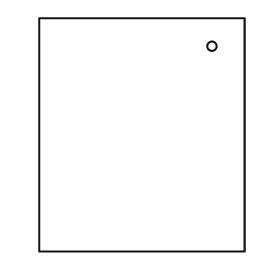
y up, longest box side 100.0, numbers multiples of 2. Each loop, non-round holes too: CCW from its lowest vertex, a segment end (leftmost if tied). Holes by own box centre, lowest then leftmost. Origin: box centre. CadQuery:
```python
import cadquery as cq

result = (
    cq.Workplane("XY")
    .moveTo(-44.0, -50.0)
    .lineTo(44.0, -50.0)
    .lineTo(44.0, 50.0)
    .lineTo(-44.0, 50.0)
    .close()
    .moveTo(30.0, 38.0)
    .circle(2.0)
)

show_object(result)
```